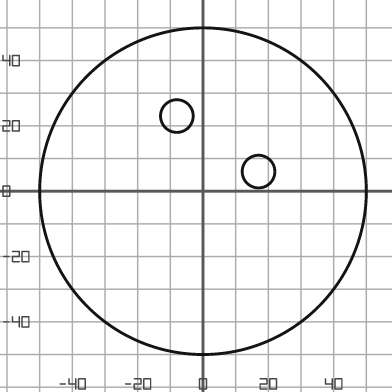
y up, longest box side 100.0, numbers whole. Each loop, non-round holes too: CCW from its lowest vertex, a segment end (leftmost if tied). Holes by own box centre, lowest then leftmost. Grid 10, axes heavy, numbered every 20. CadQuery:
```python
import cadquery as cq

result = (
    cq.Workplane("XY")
    .moveTo(0.0, 0.0)
    .circle(50.0)
    .moveTo(17.0, 6.0)
    .circle(5.0)
    .moveTo(-8.0, 23.0)
    .circle(5.0)
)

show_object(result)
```